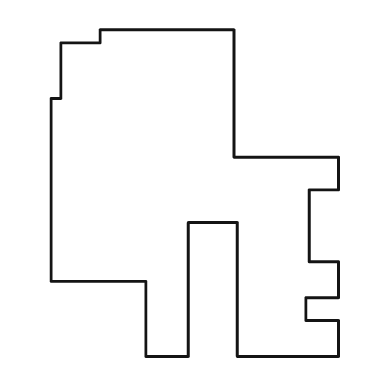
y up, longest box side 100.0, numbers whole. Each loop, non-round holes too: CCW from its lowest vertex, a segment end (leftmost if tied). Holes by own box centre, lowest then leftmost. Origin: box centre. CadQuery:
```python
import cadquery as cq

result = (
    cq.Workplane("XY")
    .moveTo(-15.0, -50.0)
    .lineTo(-2.0, -50.0)
    .lineTo(-2.0, -9.0)
    .lineTo(13.0, -9.0)
    .lineTo(13.0, -50.0)
    .lineTo(44.0, -50.0)
    .lineTo(44.0, -39.0)
    .lineTo(34.0, -39.0)
    .lineTo(34.0, -32.0)
    .lineTo(44.0, -32.0)
    .lineTo(44.0, -21.0)
    .lineTo(35.0, -21.0)
    .lineTo(35.0, 1.0)
    .lineTo(44.0, 1.0)
    .lineTo(44.0, 11.0)
    .lineTo(12.0, 11.0)
    .lineTo(12.0, 50.0)
    .lineTo(-29.0, 50.0)
    .lineTo(-29.0, 46.0)
    .lineTo(-41.0, 46.0)
    .lineTo(-41.0, 29.0)
    .lineTo(-44.0, 29.0)
    .lineTo(-44.0, -27.0)
    .lineTo(-15.0, -27.0)
    .close()
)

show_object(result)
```